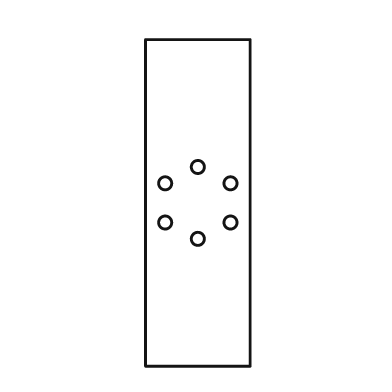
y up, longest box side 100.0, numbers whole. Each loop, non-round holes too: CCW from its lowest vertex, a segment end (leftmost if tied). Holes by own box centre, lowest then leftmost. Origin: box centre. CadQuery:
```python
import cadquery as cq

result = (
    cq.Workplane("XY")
    .moveTo(-16.0, -50.0)
    .lineTo(16.0, -50.0)
    .lineTo(16.0, 50.0)
    .lineTo(-16.0, 50.0)
    .close()
    .moveTo(0.0, -11.0)
    .circle(2.0)
    .moveTo(-10.0, -6.0)
    .circle(2.0)
    .moveTo(10.0, -6.0)
    .circle(2.0)
    .moveTo(-10.0, 6.0)
    .circle(2.0)
    .moveTo(10.0, 6.0)
    .circle(2.0)
    .moveTo(0.0, 11.0)
    .circle(2.0)
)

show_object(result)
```